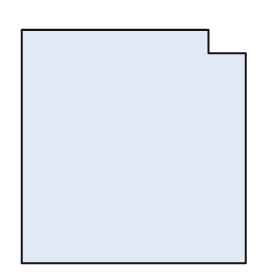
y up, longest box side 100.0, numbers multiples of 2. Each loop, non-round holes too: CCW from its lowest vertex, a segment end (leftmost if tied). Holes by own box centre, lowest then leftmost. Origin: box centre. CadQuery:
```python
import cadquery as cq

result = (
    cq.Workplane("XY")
    .moveTo(-48.0, -50.0)
    .lineTo(48.0, -50.0)
    .lineTo(48.0, 40.0)
    .lineTo(32.0, 40.0)
    .lineTo(32.0, 50.0)
    .lineTo(-48.0, 50.0)
    .close()
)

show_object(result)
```